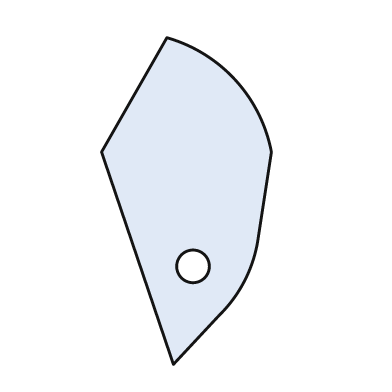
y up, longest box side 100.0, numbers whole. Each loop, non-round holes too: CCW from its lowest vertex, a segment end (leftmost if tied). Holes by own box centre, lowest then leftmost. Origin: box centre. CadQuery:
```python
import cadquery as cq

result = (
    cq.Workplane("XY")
    .moveTo(-4.0, -50.0)
    .lineTo(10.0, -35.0)
    .threePointArc((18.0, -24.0), (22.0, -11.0))
    .lineTo(26.0, 15.0)
    .threePointArc((15.0, 37.0), (-6.0, 50.0))
    .lineTo(-26.0, 15.0)
    .close()
    .moveTo(2.0, -20.0)
    .circle(5.0)
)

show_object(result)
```